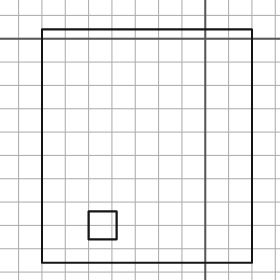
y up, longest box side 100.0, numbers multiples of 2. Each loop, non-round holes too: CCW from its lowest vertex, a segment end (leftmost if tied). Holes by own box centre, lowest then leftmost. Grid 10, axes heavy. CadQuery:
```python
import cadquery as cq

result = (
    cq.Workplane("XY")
    .moveTo(-70.0, -96.0)
    .lineTo(20.0, -96.0)
    .lineTo(20.0, 4.0)
    .lineTo(-70.0, 4.0)
    .close()
    .moveTo(-50.0, -86.0)
    .lineTo(-38.0, -86.0)
    .lineTo(-38.0, -74.0)
    .lineTo(-50.0, -74.0)
    .close()
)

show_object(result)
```